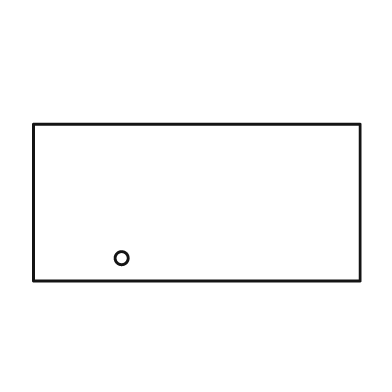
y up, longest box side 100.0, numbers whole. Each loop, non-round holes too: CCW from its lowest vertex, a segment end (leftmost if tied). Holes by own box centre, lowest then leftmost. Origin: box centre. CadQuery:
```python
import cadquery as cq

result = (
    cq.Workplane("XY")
    .moveTo(-50.0, -24.0)
    .lineTo(50.0, -24.0)
    .lineTo(50.0, 24.0)
    .lineTo(-50.0, 24.0)
    .close()
    .moveTo(-23.0, -17.0)
    .circle(2.0)
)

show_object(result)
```